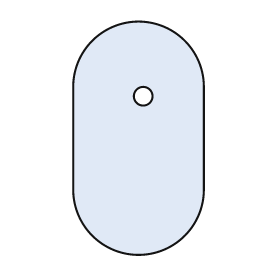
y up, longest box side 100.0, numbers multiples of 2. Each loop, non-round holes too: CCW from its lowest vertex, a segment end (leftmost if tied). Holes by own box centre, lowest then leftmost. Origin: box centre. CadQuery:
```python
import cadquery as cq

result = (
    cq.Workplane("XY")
    .moveTo(-28.0, -22.0)
    .threePointArc((0.0, -50.0), (28.0, -22.0))
    .lineTo(28.0, 22.0)
    .threePointArc((0.0, 50.0), (-28.0, 22.0))
    .close()
    .moveTo(2.0, 18.0)
    .circle(4.0)
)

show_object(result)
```